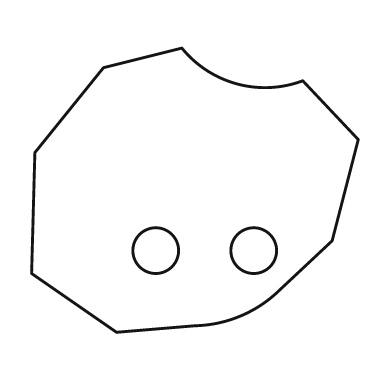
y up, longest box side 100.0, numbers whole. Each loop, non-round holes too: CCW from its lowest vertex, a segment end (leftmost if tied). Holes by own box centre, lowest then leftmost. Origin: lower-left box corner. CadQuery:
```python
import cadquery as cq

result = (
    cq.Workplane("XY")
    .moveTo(26.0, 0.0)
    .lineTo(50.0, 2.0)
    .threePointArc((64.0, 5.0), (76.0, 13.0))
    .lineTo(92.0, 28.0)
    .lineTo(100.0, 59.0)
    .lineTo(83.0, 77.0)
    .threePointArc((63.0, 76.0), (46.0, 87.0))
    .lineTo(22.0, 81.0)
    .lineTo(1.0, 55.0)
    .lineTo(0.0, 18.0)
    .close()
    .moveTo(38.0, 25.0)
    .circle(7.0)
    .moveTo(68.0, 25.0)
    .circle(7.0)
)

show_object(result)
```